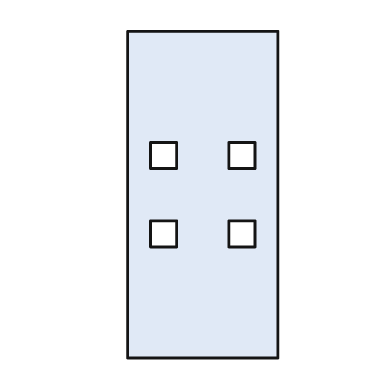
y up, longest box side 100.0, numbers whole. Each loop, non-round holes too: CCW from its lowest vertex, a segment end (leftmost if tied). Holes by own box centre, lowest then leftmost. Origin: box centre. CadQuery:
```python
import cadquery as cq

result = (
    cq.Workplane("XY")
    .moveTo(-23.0, -50.0)
    .lineTo(23.0, -50.0)
    .lineTo(23.0, 50.0)
    .lineTo(-23.0, 50.0)
    .close()
    .moveTo(-16.0, -16.0)
    .lineTo(-8.0, -16.0)
    .lineTo(-8.0, -8.0)
    .lineTo(-16.0, -8.0)
    .close()
    .moveTo(8.0, -16.0)
    .lineTo(16.0, -16.0)
    .lineTo(16.0, -8.0)
    .lineTo(8.0, -8.0)
    .close()
    .moveTo(-16.0, 8.0)
    .lineTo(-8.0, 8.0)
    .lineTo(-8.0, 16.0)
    .lineTo(-16.0, 16.0)
    .close()
    .moveTo(8.0, 8.0)
    .lineTo(16.0, 8.0)
    .lineTo(16.0, 16.0)
    .lineTo(8.0, 16.0)
    .close()
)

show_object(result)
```